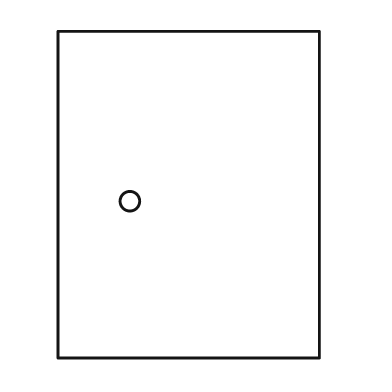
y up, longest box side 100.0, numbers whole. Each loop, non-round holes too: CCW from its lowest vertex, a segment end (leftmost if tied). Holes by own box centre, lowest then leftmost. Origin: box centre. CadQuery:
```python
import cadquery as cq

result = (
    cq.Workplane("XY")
    .moveTo(-40.0, -50.0)
    .lineTo(40.0, -50.0)
    .lineTo(40.0, 50.0)
    .lineTo(-40.0, 50.0)
    .close()
    .moveTo(-18.0, -2.0)
    .circle(3.0)
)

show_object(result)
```